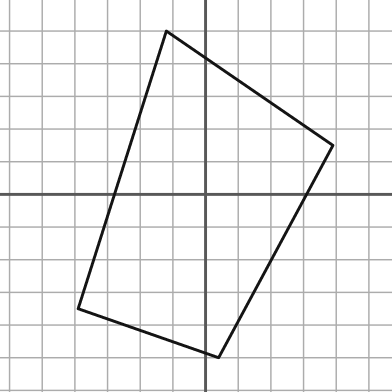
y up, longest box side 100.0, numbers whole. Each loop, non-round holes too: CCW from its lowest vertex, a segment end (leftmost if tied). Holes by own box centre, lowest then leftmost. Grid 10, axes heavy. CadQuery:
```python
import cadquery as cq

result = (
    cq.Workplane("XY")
    .moveTo(4.0, -50.0)
    .lineTo(39.0, 15.0)
    .lineTo(-12.0, 50.0)
    .lineTo(-39.0, -35.0)
    .close()
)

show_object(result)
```